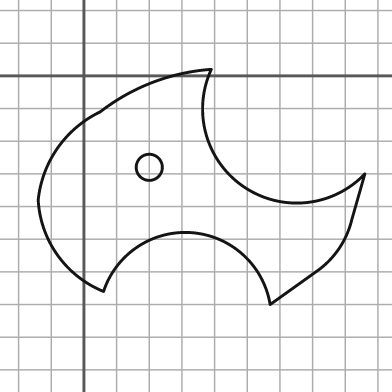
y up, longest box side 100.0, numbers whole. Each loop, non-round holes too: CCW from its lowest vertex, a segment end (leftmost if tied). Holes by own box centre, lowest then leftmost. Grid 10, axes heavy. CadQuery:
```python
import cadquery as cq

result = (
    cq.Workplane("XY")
    .moveTo(57.0, -70.0)
    .lineTo(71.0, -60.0)
    .threePointArc((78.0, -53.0), (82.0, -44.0))
    .lineTo(86.0, -30.0)
    .threePointArc((49.0, -34.0), (39.0, 2.0))
    .threePointArc((21.0, -2.0), (5.0, -11.0))
    .threePointArc((-8.0, -22.0), (-14.0, -38.0))
    .threePointArc((-8.0, -55.0), (6.0, -66.0))
    .threePointArc((33.0, -48.0), (57.0, -70.0))
    .close()
    .moveTo(20.0, -28.0)
    .circle(4.0)
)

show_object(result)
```